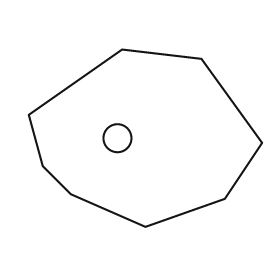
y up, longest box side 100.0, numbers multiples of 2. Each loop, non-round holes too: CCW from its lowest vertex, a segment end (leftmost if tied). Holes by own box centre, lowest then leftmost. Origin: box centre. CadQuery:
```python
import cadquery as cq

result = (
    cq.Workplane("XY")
    .moveTo(0.0, -38.0)
    .lineTo(34.0, -26.0)
    .lineTo(50.0, -2.0)
    .lineTo(24.0, 34.0)
    .lineTo(-10.0, 38.0)
    .lineTo(-50.0, 10.0)
    .lineTo(-44.0, -12.0)
    .lineTo(-32.0, -24.0)
    .close()
    .moveTo(-12.0, 0.0)
    .circle(6.0)
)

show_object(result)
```